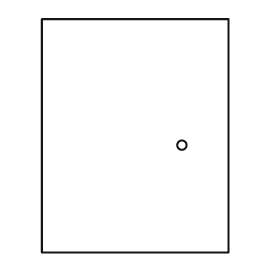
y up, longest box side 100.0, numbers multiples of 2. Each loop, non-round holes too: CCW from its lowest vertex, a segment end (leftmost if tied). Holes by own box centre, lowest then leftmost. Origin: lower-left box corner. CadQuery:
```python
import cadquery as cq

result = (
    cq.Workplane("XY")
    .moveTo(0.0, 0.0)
    .lineTo(80.0, 0.0)
    .lineTo(80.0, 100.0)
    .lineTo(0.0, 100.0)
    .close()
    .moveTo(60.0, 46.0)
    .circle(2.0)
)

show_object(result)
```